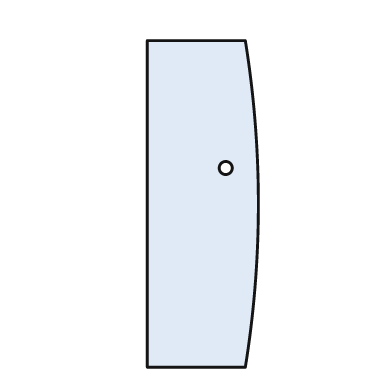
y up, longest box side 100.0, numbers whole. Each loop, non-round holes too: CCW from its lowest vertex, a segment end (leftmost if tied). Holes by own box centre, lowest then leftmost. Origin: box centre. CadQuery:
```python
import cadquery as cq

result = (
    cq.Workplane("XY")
    .moveTo(-17.0, -50.0)
    .lineTo(13.0, -50.0)
    .threePointArc((17.0, 0.0), (13.0, 50.0))
    .lineTo(-17.0, 50.0)
    .close()
    .moveTo(7.0, 11.0)
    .circle(2.0)
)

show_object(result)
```